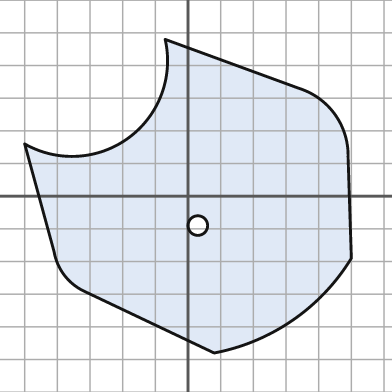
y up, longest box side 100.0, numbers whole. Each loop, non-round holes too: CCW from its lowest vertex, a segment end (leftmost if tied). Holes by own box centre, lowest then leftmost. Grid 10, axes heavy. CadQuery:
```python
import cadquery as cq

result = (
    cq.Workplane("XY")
    .moveTo(8.0, -48.0)
    .threePointArc((32.0, -38.0), (50.0, -19.0))
    .lineTo(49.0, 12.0)
    .threePointArc((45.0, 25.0), (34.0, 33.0))
    .lineTo(-7.0, 48.0)
    .threePointArc((-18.0, 18.0), (-50.0, 16.0))
    .lineTo(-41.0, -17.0)
    .threePointArc((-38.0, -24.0), (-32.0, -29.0))
    .close()
    .moveTo(3.0, -9.0)
    .circle(3.0)
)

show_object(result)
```